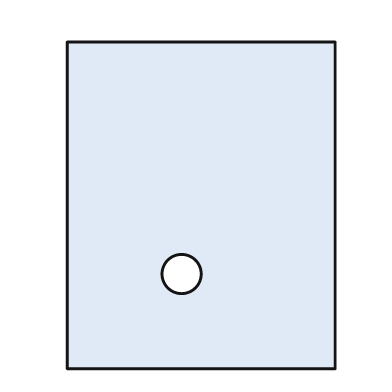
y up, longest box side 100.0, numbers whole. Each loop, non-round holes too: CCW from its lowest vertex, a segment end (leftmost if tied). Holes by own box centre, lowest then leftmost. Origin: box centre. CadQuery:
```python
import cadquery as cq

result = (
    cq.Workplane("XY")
    .moveTo(-41.0, -50.0)
    .lineTo(41.0, -50.0)
    .lineTo(41.0, 50.0)
    .lineTo(-41.0, 50.0)
    .close()
    .moveTo(-6.0, -21.0)
    .circle(6.0)
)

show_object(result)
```